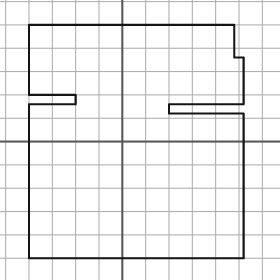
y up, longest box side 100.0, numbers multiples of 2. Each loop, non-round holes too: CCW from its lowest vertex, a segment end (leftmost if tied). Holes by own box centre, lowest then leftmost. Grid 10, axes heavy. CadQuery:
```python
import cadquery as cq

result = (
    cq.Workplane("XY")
    .moveTo(-40.0, -50.0)
    .lineTo(52.0, -50.0)
    .lineTo(52.0, 12.0)
    .lineTo(20.0, 12.0)
    .lineTo(20.0, 16.0)
    .lineTo(52.0, 16.0)
    .lineTo(52.0, 36.0)
    .lineTo(48.0, 36.0)
    .lineTo(48.0, 50.0)
    .lineTo(-40.0, 50.0)
    .lineTo(-40.0, 20.0)
    .lineTo(-20.0, 20.0)
    .lineTo(-20.0, 16.0)
    .lineTo(-40.0, 16.0)
    .close()
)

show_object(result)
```